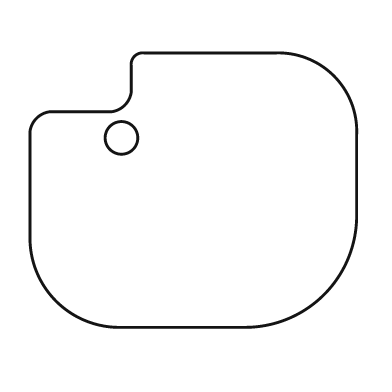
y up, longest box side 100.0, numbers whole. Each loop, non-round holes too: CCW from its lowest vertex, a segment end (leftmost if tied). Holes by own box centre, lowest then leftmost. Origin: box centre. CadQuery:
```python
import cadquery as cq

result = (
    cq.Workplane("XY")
    .moveTo(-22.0, -42.0)
    .lineTo(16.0, -42.0)
    .threePointArc((40.0, -32.0), (50.0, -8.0))
    .lineTo(50.0, 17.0)
    .threePointArc((43.0, 35.0), (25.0, 42.0))
    .lineTo(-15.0, 42.0)
    .threePointArc((-18.0, 41.0), (-19.0, 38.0))
    .lineTo(-19.0, 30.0)
    .threePointArc((-21.0, 26.0), (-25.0, 24.0))
    .lineTo(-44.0, 24.0)
    .threePointArc((-48.0, 22.0), (-50.0, 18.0))
    .lineTo(-50.0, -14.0)
    .threePointArc((-42.0, -34.0), (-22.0, -42.0))
    .close()
    .moveTo(-22.0, 16.0)
    .circle(5.0)
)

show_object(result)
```